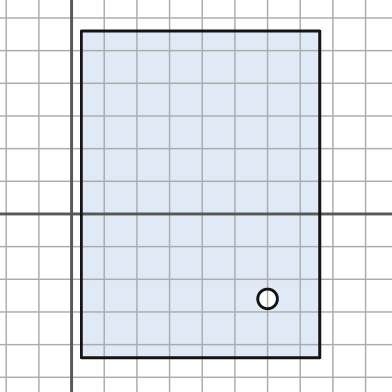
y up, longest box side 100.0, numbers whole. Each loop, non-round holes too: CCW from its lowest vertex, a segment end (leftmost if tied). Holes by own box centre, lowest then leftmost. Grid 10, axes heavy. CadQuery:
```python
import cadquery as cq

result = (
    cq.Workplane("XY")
    .moveTo(3.0, -44.0)
    .lineTo(76.0, -44.0)
    .lineTo(76.0, 56.0)
    .lineTo(3.0, 56.0)
    .close()
    .moveTo(60.0, -26.0)
    .circle(3.0)
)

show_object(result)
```